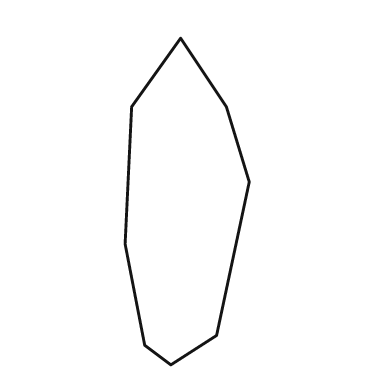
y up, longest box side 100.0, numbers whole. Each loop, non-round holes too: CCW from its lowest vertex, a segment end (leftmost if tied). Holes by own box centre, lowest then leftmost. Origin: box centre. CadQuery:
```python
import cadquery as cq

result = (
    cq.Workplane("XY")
    .moveTo(-5.0, -50.0)
    .lineTo(9.0, -41.0)
    .lineTo(19.0, 6.0)
    .lineTo(12.0, 29.0)
    .lineTo(-2.0, 50.0)
    .lineTo(-17.0, 29.0)
    .lineTo(-19.0, -13.0)
    .lineTo(-13.0, -44.0)
    .close()
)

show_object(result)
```